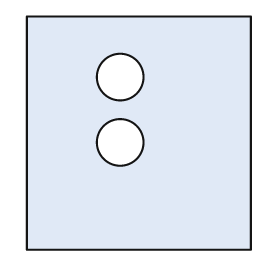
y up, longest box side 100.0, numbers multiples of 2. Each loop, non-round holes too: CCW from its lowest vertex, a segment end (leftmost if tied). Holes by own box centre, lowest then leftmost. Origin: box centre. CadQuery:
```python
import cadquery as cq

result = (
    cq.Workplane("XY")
    .moveTo(-48.0, -50.0)
    .lineTo(48.0, -50.0)
    .lineTo(48.0, 50.0)
    .lineTo(-48.0, 50.0)
    .close()
    .moveTo(-8.0, -4.0)
    .circle(10.0)
    .moveTo(-8.0, 24.0)
    .circle(10.0)
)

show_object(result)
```